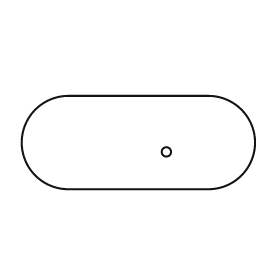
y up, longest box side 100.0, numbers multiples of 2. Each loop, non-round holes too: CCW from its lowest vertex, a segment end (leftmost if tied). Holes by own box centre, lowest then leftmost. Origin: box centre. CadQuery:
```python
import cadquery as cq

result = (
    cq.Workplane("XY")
    .moveTo(-30.0, -20.0)
    .lineTo(30.0, -20.0)
    .threePointArc((50.0, 0.0), (30.0, 20.0))
    .lineTo(-30.0, 20.0)
    .threePointArc((-50.0, 0.0), (-30.0, -20.0))
    .close()
    .moveTo(12.0, -4.0)
    .circle(2.0)
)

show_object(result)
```